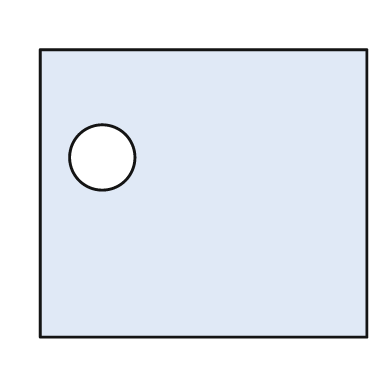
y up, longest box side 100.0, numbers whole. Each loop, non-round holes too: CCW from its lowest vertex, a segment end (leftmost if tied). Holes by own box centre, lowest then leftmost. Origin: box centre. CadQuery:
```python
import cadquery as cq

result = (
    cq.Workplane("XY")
    .moveTo(-50.0, -44.0)
    .lineTo(50.0, -44.0)
    .lineTo(50.0, 44.0)
    .lineTo(-50.0, 44.0)
    .close()
    .moveTo(-31.0, 11.0)
    .circle(10.0)
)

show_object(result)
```